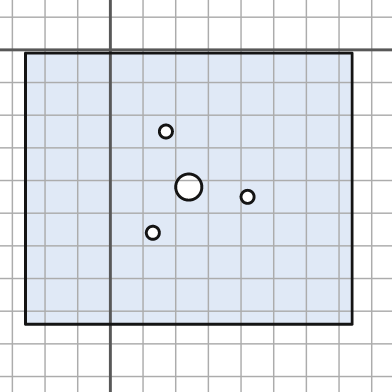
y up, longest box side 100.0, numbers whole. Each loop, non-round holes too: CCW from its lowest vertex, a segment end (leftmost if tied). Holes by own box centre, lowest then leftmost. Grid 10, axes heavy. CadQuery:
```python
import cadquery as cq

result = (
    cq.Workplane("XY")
    .moveTo(-26.0, -84.0)
    .lineTo(74.0, -84.0)
    .lineTo(74.0, -1.0)
    .lineTo(-26.0, -1.0)
    .close()
    .moveTo(13.0, -56.0)
    .circle(2.0)
    .moveTo(42.0, -45.0)
    .circle(2.0)
    .moveTo(24.0, -42.0)
    .circle(4.0)
    .moveTo(17.0, -25.0)
    .circle(2.0)
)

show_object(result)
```